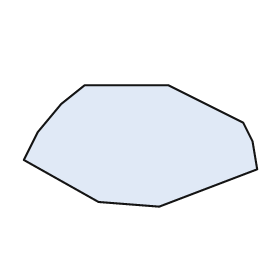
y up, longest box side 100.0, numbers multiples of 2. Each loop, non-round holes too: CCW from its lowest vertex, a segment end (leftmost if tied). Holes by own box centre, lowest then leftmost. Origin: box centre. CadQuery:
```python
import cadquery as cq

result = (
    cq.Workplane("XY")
    .moveTo(8.0, -26.0)
    .lineTo(50.0, -10.0)
    .lineTo(48.0, 2.0)
    .lineTo(44.0, 10.0)
    .lineTo(12.0, 26.0)
    .lineTo(-24.0, 26.0)
    .lineTo(-34.0, 18.0)
    .lineTo(-44.0, 6.0)
    .lineTo(-50.0, -6.0)
    .lineTo(-18.0, -24.0)
    .close()
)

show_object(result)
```